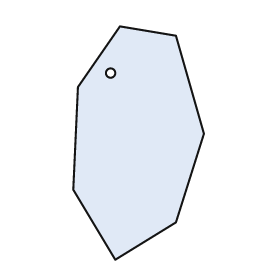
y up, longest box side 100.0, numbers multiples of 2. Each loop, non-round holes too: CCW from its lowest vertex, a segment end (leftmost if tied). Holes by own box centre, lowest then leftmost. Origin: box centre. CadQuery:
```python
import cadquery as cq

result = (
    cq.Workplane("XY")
    .moveTo(-10.0, -50.0)
    .lineTo(16.0, -34.0)
    .lineTo(28.0, 4.0)
    .lineTo(16.0, 46.0)
    .lineTo(-8.0, 50.0)
    .lineTo(-26.0, 24.0)
    .lineTo(-28.0, -20.0)
    .close()
    .moveTo(-12.0, 30.0)
    .circle(2.0)
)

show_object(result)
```